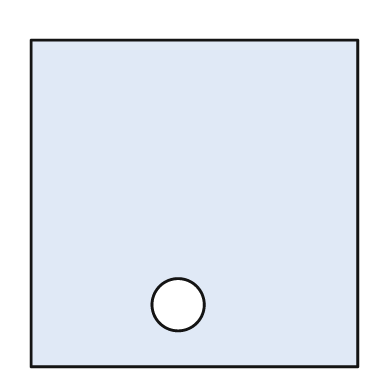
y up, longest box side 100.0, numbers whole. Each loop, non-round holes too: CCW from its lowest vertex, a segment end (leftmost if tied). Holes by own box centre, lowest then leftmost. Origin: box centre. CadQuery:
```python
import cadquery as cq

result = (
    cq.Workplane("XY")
    .moveTo(-50.0, -50.0)
    .lineTo(50.0, -50.0)
    .lineTo(50.0, 50.0)
    .lineTo(-50.0, 50.0)
    .close()
    .moveTo(-5.0, -31.0)
    .circle(8.0)
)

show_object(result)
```